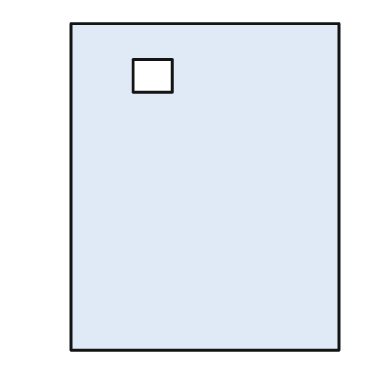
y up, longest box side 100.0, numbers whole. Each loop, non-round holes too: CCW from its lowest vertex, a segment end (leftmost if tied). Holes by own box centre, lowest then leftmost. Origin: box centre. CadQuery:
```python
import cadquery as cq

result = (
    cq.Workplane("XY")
    .moveTo(-41.0, -50.0)
    .lineTo(41.0, -50.0)
    .lineTo(41.0, 50.0)
    .lineTo(-41.0, 50.0)
    .close()
    .moveTo(-22.0, 29.0)
    .lineTo(-10.0, 29.0)
    .lineTo(-10.0, 39.0)
    .lineTo(-22.0, 39.0)
    .close()
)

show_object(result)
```